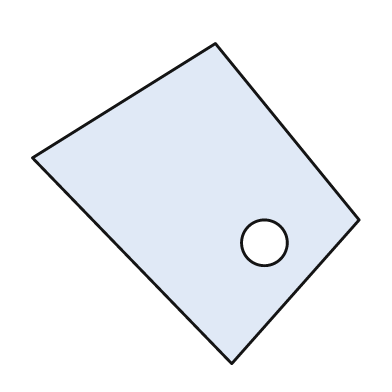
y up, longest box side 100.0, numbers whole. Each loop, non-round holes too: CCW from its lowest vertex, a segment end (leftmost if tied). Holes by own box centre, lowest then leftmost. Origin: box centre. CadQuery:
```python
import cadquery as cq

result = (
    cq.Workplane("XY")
    .moveTo(11.0, -49.0)
    .lineTo(50.0, -5.0)
    .lineTo(6.0, 49.0)
    .lineTo(-50.0, 14.0)
    .close()
    .moveTo(21.0, -12.0)
    .circle(7.0)
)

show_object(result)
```